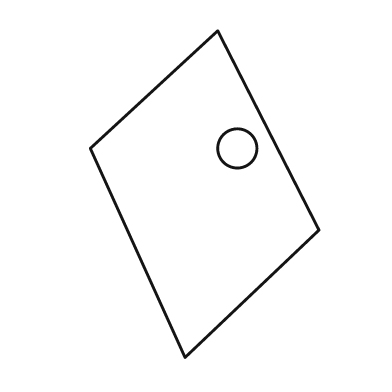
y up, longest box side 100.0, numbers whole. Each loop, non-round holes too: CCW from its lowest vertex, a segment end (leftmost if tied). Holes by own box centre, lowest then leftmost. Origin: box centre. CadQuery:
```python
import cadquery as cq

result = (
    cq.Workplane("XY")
    .moveTo(-6.0, -50.0)
    .lineTo(35.0, -11.0)
    .lineTo(4.0, 50.0)
    .lineTo(-35.0, 14.0)
    .close()
    .moveTo(10.0, 14.0)
    .circle(6.0)
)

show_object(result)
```